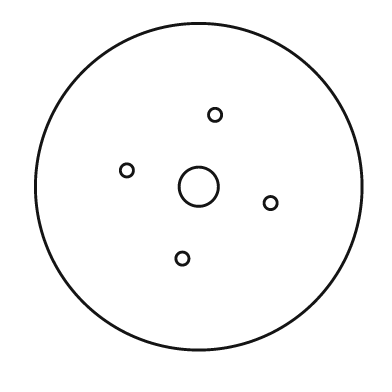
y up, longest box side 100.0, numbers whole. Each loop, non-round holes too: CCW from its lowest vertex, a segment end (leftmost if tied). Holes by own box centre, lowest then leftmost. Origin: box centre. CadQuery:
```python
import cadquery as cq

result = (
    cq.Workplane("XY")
    .moveTo(0.0, 0.0)
    .circle(50.0)
    .moveTo(-5.0, -22.0)
    .circle(2.0)
    .moveTo(22.0, -5.0)
    .circle(2.0)
    .moveTo(0.0, 0.0)
    .circle(6.0)
    .moveTo(-22.0, 5.0)
    .circle(2.0)
    .moveTo(5.0, 22.0)
    .circle(2.0)
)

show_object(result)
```